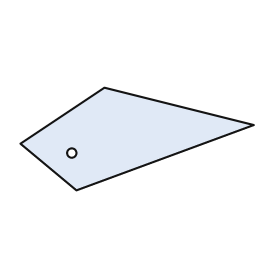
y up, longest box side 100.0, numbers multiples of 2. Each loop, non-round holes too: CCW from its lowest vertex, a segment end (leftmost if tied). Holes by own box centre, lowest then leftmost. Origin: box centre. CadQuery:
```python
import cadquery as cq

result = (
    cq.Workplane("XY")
    .moveTo(-26.0, -22.0)
    .lineTo(50.0, 6.0)
    .lineTo(-14.0, 22.0)
    .lineTo(-50.0, -2.0)
    .close()
    .moveTo(-28.0, -6.0)
    .circle(2.0)
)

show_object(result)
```